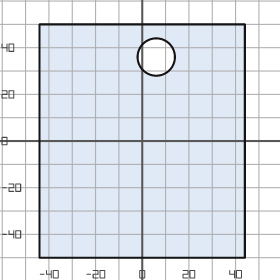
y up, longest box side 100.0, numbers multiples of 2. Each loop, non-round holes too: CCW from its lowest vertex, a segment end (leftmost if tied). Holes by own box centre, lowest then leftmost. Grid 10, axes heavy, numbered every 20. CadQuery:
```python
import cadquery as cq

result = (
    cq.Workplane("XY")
    .moveTo(-44.0, -50.0)
    .lineTo(44.0, -50.0)
    .lineTo(44.0, 50.0)
    .lineTo(-44.0, 50.0)
    .close()
    .moveTo(6.0, 36.0)
    .circle(8.0)
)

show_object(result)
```